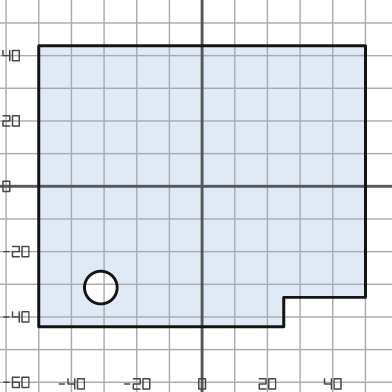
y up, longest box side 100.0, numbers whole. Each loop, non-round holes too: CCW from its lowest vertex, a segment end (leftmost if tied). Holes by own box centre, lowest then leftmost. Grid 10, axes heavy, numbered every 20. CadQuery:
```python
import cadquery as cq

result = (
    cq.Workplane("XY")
    .moveTo(-50.0, -43.0)
    .lineTo(25.0, -43.0)
    .lineTo(25.0, -34.0)
    .lineTo(50.0, -34.0)
    .lineTo(50.0, 43.0)
    .lineTo(-50.0, 43.0)
    .close()
    .moveTo(-31.0, -31.0)
    .circle(5.0)
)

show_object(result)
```